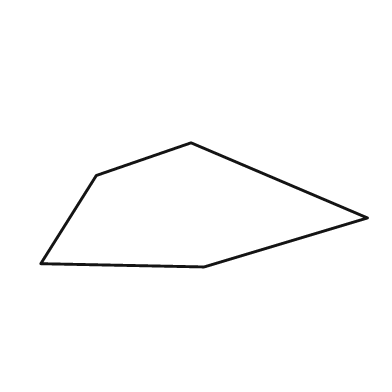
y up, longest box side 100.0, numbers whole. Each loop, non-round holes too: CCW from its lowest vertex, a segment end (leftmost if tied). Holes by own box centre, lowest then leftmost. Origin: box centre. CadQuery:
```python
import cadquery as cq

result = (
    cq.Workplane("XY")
    .moveTo(0.0, -19.0)
    .lineTo(50.0, -4.0)
    .lineTo(-4.0, 19.0)
    .lineTo(-33.0, 9.0)
    .lineTo(-50.0, -18.0)
    .close()
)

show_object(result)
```